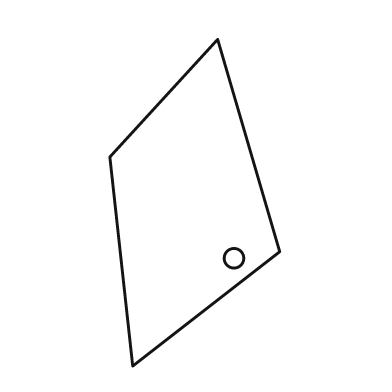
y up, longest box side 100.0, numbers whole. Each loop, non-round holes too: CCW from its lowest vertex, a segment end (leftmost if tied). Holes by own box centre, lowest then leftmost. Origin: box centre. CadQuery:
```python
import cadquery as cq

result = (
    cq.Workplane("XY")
    .moveTo(-19.0, -50.0)
    .lineTo(26.0, -15.0)
    .lineTo(7.0, 50.0)
    .lineTo(-26.0, 14.0)
    .close()
    .moveTo(12.0, -17.0)
    .circle(3.0)
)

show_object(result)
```